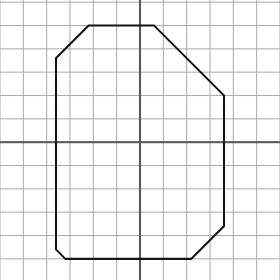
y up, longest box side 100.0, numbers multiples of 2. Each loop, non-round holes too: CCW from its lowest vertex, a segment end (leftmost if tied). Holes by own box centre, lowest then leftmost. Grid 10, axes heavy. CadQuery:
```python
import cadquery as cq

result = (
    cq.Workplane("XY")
    .moveTo(-32.0, -50.0)
    .lineTo(22.0, -50.0)
    .lineTo(36.0, -36.0)
    .lineTo(36.0, 20.0)
    .lineTo(6.0, 50.0)
    .lineTo(-22.0, 50.0)
    .lineTo(-36.0, 36.0)
    .lineTo(-36.0, -46.0)
    .close()
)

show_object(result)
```